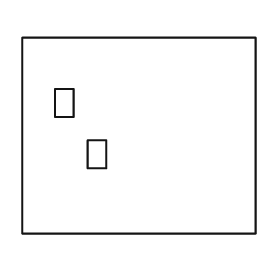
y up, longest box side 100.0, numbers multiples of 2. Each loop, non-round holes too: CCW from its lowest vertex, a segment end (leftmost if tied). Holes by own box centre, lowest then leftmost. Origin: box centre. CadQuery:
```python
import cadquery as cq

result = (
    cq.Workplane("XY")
    .moveTo(-50.0, -42.0)
    .lineTo(50.0, -42.0)
    .lineTo(50.0, 42.0)
    .lineTo(-50.0, 42.0)
    .close()
    .moveTo(-22.0, -14.0)
    .lineTo(-14.0, -14.0)
    .lineTo(-14.0, -2.0)
    .lineTo(-22.0, -2.0)
    .close()
    .moveTo(-36.0, 8.0)
    .lineTo(-28.0, 8.0)
    .lineTo(-28.0, 20.0)
    .lineTo(-36.0, 20.0)
    .close()
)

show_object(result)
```